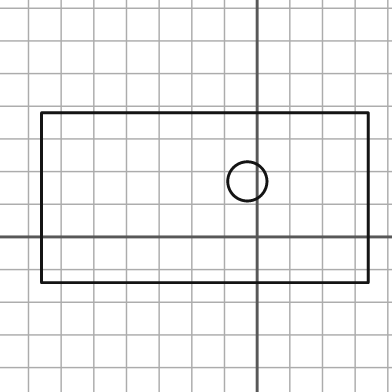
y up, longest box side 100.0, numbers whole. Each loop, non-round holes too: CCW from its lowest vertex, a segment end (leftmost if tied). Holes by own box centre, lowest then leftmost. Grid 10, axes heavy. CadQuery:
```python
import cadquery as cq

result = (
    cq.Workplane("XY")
    .moveTo(-66.0, -14.0)
    .lineTo(34.0, -14.0)
    .lineTo(34.0, 38.0)
    .lineTo(-66.0, 38.0)
    .close()
    .moveTo(-3.0, 17.0)
    .circle(6.0)
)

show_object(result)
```